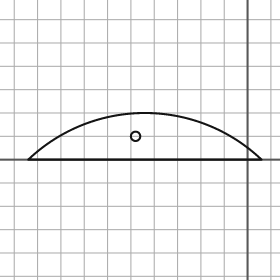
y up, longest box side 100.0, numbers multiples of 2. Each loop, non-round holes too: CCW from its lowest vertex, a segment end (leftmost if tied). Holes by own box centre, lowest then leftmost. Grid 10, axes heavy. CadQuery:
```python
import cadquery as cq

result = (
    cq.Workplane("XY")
    .moveTo(-94.0, 0.0)
    .lineTo(6.0, 0.0)
    .threePointArc((-44.0, 20.0), (-94.0, 0.0))
    .close()
    .moveTo(-48.0, 10.0)
    .circle(2.0)
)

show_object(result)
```